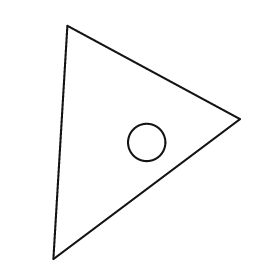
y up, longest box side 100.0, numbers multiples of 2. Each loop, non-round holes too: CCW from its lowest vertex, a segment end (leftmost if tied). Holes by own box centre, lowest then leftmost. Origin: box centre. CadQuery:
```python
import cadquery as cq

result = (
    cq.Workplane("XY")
    .moveTo(-40.0, -50.0)
    .lineTo(40.0, 10.0)
    .lineTo(-34.0, 50.0)
    .close()
    .moveTo(0.0, 0.0)
    .circle(8.0)
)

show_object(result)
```